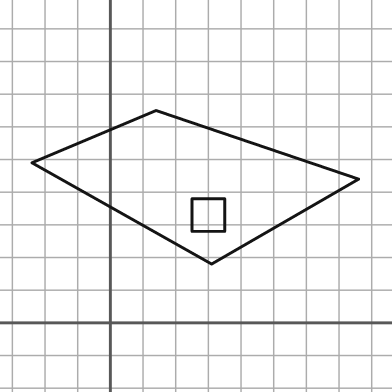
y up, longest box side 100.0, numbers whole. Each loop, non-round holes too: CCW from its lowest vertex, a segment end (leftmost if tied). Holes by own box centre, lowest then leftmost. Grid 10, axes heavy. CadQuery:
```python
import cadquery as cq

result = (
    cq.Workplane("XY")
    .moveTo(31.0, 18.0)
    .lineTo(76.0, 44.0)
    .lineTo(14.0, 65.0)
    .lineTo(-24.0, 49.0)
    .close()
    .moveTo(25.0, 28.0)
    .lineTo(35.0, 28.0)
    .lineTo(35.0, 38.0)
    .lineTo(25.0, 38.0)
    .close()
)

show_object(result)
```